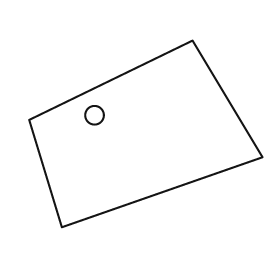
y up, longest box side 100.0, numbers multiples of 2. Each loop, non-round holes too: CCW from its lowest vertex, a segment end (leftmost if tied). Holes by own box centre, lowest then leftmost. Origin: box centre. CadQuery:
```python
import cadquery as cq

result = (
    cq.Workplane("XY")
    .moveTo(-36.0, -40.0)
    .lineTo(50.0, -10.0)
    .lineTo(20.0, 40.0)
    .lineTo(-50.0, 6.0)
    .close()
    .moveTo(-22.0, 8.0)
    .circle(4.0)
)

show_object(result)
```